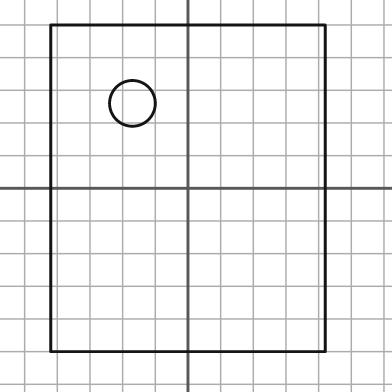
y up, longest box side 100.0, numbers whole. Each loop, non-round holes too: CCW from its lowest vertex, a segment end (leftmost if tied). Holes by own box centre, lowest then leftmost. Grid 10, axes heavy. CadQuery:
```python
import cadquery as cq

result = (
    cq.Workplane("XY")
    .moveTo(-42.0, -50.0)
    .lineTo(42.0, -50.0)
    .lineTo(42.0, 50.0)
    .lineTo(-42.0, 50.0)
    .close()
    .moveTo(-17.0, 26.0)
    .circle(7.0)
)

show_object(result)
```